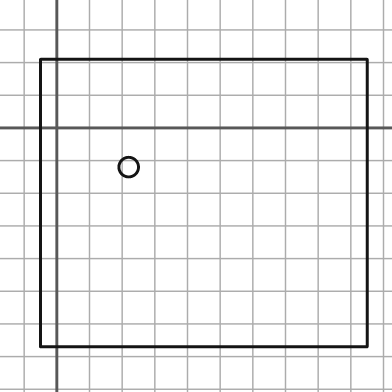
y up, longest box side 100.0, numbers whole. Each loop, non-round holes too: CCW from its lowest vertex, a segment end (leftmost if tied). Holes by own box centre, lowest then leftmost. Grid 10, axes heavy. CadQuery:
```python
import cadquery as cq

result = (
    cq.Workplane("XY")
    .moveTo(-5.0, -67.0)
    .lineTo(95.0, -67.0)
    .lineTo(95.0, 21.0)
    .lineTo(-5.0, 21.0)
    .close()
    .moveTo(22.0, -12.0)
    .circle(3.0)
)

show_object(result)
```